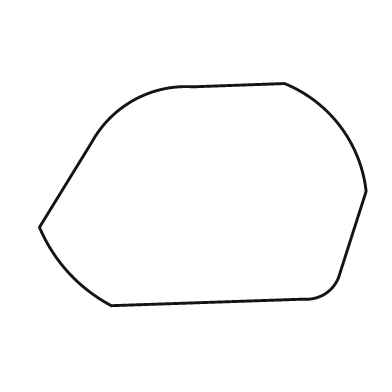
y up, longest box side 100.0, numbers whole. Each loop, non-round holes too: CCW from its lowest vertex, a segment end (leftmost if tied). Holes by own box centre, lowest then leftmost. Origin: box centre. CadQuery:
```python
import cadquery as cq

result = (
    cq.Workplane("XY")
    .moveTo(-28.0, -34.0)
    .lineTo(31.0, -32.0)
    .threePointArc((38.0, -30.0), (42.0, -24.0))
    .lineTo(50.0, 1.0)
    .threePointArc((42.0, 21.0), (25.0, 34.0))
    .lineTo(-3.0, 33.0)
    .threePointArc((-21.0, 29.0), (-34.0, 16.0))
    .lineTo(-50.0, -10.0)
    .threePointArc((-41.0, -24.0), (-28.0, -34.0))
    .close()
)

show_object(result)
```